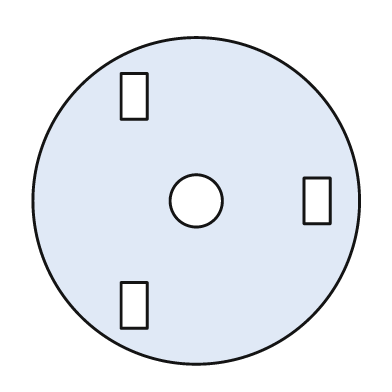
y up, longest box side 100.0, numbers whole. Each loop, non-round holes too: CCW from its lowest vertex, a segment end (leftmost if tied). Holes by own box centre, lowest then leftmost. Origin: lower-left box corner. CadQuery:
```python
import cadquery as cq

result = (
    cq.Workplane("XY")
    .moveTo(50.0, 50.0)
    .circle(50.0)
    .moveTo(27.0, 11.0)
    .lineTo(35.0, 11.0)
    .lineTo(35.0, 25.0)
    .lineTo(27.0, 25.0)
    .close()
    .moveTo(50.0, 50.0)
    .circle(8.0)
    .moveTo(83.0, 43.0)
    .lineTo(91.0, 43.0)
    .lineTo(91.0, 57.0)
    .lineTo(83.0, 57.0)
    .close()
    .moveTo(27.0, 75.0)
    .lineTo(35.0, 75.0)
    .lineTo(35.0, 89.0)
    .lineTo(27.0, 89.0)
    .close()
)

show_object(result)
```